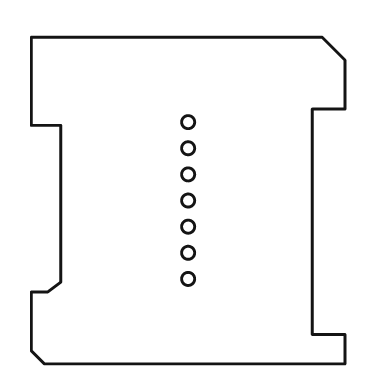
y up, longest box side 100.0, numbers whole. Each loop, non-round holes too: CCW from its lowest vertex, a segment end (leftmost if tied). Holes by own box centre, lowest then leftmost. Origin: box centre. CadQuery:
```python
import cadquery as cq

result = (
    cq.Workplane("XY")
    .moveTo(-44.0, -50.0)
    .lineTo(48.0, -50.0)
    .lineTo(48.0, -41.0)
    .lineTo(38.0, -41.0)
    .lineTo(38.0, 28.0)
    .lineTo(48.0, 28.0)
    .lineTo(48.0, 43.0)
    .lineTo(41.0, 50.0)
    .lineTo(-48.0, 50.0)
    .lineTo(-48.0, 23.0)
    .lineTo(-39.0, 23.0)
    .lineTo(-39.0, -25.0)
    .lineTo(-43.0, -28.0)
    .lineTo(-48.0, -28.0)
    .lineTo(-48.0, -46.0)
    .close()
    .moveTo(0.0, -24.0)
    .circle(2.0)
    .moveTo(0.0, -16.0)
    .circle(2.0)
    .moveTo(0.0, -8.0)
    .circle(2.0)
    .moveTo(0.0, 0.0)
    .circle(2.0)
    .moveTo(0.0, 8.0)
    .circle(2.0)
    .moveTo(0.0, 16.0)
    .circle(2.0)
    .moveTo(0.0, 24.0)
    .circle(2.0)
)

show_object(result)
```